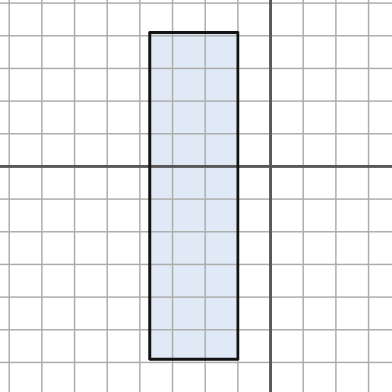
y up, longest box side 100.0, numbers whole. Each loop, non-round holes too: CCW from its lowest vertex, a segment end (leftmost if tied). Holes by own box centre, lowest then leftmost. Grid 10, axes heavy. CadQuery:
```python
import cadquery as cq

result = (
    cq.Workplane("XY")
    .moveTo(-37.0, -59.0)
    .lineTo(-10.0, -59.0)
    .lineTo(-10.0, 41.0)
    .lineTo(-37.0, 41.0)
    .close()
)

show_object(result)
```